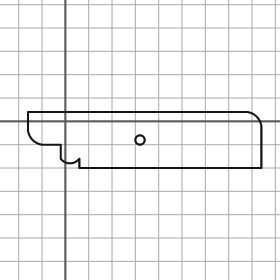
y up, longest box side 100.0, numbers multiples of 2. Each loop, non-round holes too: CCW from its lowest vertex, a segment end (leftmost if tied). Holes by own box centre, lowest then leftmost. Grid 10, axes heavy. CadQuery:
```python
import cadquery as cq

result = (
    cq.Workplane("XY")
    .moveTo(6.0, -20.0)
    .lineTo(84.0, -20.0)
    .lineTo(84.0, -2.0)
    .threePointArc((82.0, 2.0), (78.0, 4.0))
    .lineTo(-16.0, 4.0)
    .lineTo(-16.0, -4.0)
    .threePointArc((-14.0, -8.0), (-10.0, -10.0))
    .lineTo(-2.0, -10.0)
    .lineTo(-2.0, -16.0)
    .threePointArc((2.0, -18.0), (6.0, -16.0))
    .close()
    .moveTo(32.0, -8.0)
    .circle(2.0)
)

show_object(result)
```